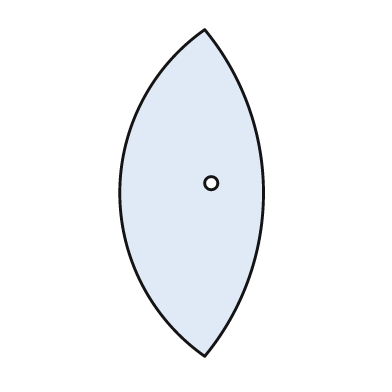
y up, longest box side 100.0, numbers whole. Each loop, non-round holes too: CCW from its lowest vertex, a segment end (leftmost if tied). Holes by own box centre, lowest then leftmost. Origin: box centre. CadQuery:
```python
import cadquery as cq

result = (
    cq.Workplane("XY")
    .moveTo(4.0, -50.0)
    .threePointArc((22.0, 0.0), (4.0, 50.0))
    .threePointArc((-22.0, 0.0), (4.0, -50.0))
    .close()
    .moveTo(6.0, 3.0)
    .circle(2.0)
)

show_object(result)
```